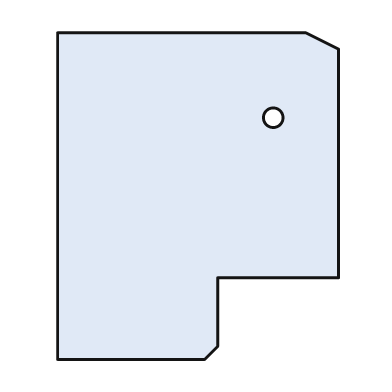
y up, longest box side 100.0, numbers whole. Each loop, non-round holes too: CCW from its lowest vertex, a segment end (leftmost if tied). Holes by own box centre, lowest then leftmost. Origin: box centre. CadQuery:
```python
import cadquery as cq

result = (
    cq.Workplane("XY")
    .moveTo(-43.0, -50.0)
    .lineTo(2.0, -50.0)
    .lineTo(6.0, -46.0)
    .lineTo(6.0, -25.0)
    .lineTo(43.0, -25.0)
    .lineTo(43.0, 45.0)
    .lineTo(33.0, 50.0)
    .lineTo(-43.0, 50.0)
    .close()
    .moveTo(23.0, 24.0)
    .circle(3.0)
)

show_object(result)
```